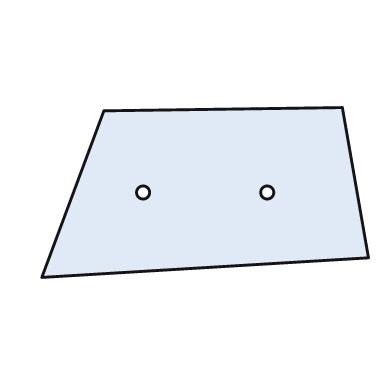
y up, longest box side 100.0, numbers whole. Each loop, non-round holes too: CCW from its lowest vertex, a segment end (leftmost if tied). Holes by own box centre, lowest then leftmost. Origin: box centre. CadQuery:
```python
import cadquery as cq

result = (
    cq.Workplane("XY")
    .moveTo(-50.0, -26.0)
    .lineTo(50.0, -20.0)
    .lineTo(42.0, 26.0)
    .lineTo(-31.0, 25.0)
    .close()
    .moveTo(-19.0, 0.0)
    .circle(2.0)
    .moveTo(19.0, 0.0)
    .circle(2.0)
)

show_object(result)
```